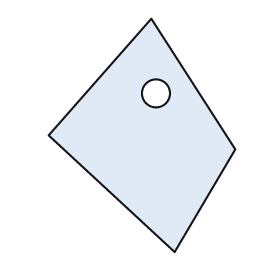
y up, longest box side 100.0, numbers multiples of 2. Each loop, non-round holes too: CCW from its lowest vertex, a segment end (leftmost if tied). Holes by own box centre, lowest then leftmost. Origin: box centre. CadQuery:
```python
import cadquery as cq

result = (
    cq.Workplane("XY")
    .moveTo(14.0, -50.0)
    .lineTo(40.0, -6.0)
    .lineTo(4.0, 50.0)
    .lineTo(-40.0, 0.0)
    .close()
    .moveTo(6.0, 18.0)
    .circle(6.0)
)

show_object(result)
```